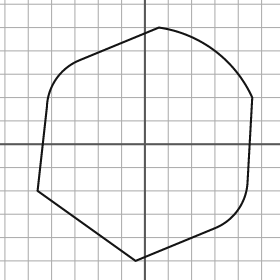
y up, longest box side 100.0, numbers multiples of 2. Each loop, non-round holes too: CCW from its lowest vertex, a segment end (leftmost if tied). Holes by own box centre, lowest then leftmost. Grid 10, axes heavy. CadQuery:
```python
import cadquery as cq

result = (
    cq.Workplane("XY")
    .moveTo(-4.0, -50.0)
    .lineTo(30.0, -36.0)
    .threePointArc((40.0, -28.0), (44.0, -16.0))
    .lineTo(46.0, 20.0)
    .threePointArc((30.0, 40.0), (6.0, 50.0))
    .lineTo(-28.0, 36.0)
    .threePointArc((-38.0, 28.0), (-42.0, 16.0))
    .lineTo(-46.0, -20.0)
    .close()
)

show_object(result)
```